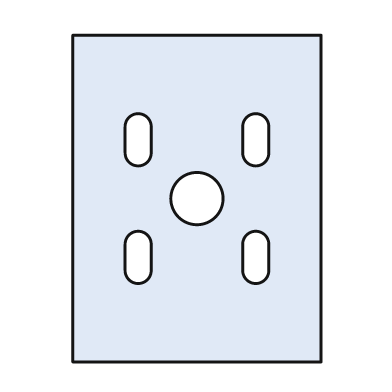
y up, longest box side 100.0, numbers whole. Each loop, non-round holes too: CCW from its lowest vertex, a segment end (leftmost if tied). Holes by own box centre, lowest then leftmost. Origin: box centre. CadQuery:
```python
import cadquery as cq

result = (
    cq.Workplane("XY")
    .moveTo(-38.0, -50.0)
    .lineTo(38.0, -50.0)
    .lineTo(38.0, 50.0)
    .lineTo(-38.0, 50.0)
    .close()
    .moveTo(-22.0, -22.0)
    .threePointArc((-18.0, -26.0), (-14.0, -22.0))
    .lineTo(-14.0, -14.0)
    .threePointArc((-18.0, -10.0), (-22.0, -14.0))
    .close()
    .moveTo(14.0, -22.0)
    .threePointArc((18.0, -26.0), (22.0, -22.0))
    .lineTo(22.0, -14.0)
    .threePointArc((18.0, -10.0), (14.0, -14.0))
    .close()
    .moveTo(0.0, 0.0)
    .circle(8.0)
    .moveTo(-22.0, 14.0)
    .threePointArc((-18.0, 10.0), (-14.0, 14.0))
    .lineTo(-14.0, 22.0)
    .threePointArc((-18.0, 26.0), (-22.0, 22.0))
    .close()
    .moveTo(14.0, 14.0)
    .threePointArc((18.0, 10.0), (22.0, 14.0))
    .lineTo(22.0, 22.0)
    .threePointArc((18.0, 26.0), (14.0, 22.0))
    .close()
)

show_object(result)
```